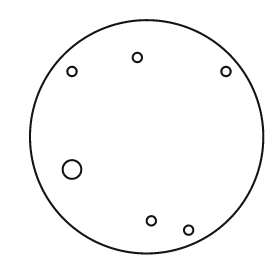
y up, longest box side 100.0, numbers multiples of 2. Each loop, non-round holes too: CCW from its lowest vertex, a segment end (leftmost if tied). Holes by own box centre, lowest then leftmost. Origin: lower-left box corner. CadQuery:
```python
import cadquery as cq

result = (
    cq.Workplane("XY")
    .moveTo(50.0, 50.0)
    .circle(50.0)
    .moveTo(68.0, 10.0)
    .circle(2.0)
    .moveTo(52.0, 14.0)
    .circle(2.0)
    .moveTo(18.0, 36.0)
    .circle(4.0)
    .moveTo(18.0, 78.0)
    .circle(2.0)
    .moveTo(84.0, 78.0)
    .circle(2.0)
    .moveTo(46.0, 84.0)
    .circle(2.0)
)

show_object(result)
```